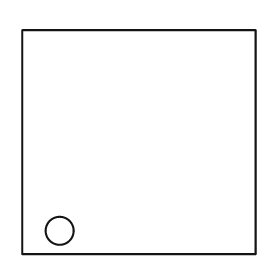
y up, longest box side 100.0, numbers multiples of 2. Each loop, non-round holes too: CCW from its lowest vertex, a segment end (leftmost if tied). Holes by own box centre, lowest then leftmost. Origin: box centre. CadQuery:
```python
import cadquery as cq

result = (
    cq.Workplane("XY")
    .moveTo(-50.0, -48.0)
    .lineTo(50.0, -48.0)
    .lineTo(50.0, 48.0)
    .lineTo(-50.0, 48.0)
    .close()
    .moveTo(-34.0, -38.0)
    .circle(6.0)
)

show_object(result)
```